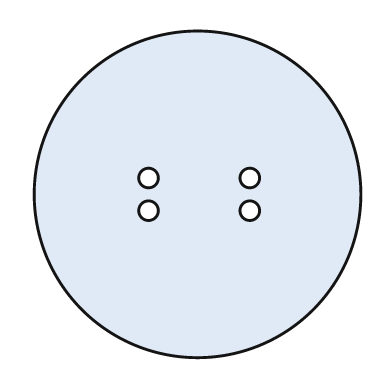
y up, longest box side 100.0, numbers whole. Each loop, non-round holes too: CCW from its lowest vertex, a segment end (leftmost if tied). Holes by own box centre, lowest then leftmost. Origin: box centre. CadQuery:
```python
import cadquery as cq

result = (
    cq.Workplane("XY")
    .moveTo(0.0, 0.0)
    .circle(50.0)
    .moveTo(-15.0, -5.0)
    .circle(3.0)
    .moveTo(16.0, -5.0)
    .circle(3.0)
    .moveTo(-15.0, 5.0)
    .circle(3.0)
    .moveTo(16.0, 5.0)
    .circle(3.0)
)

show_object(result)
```